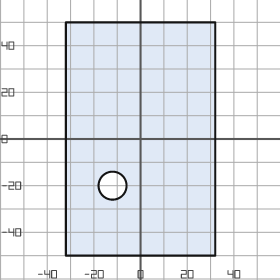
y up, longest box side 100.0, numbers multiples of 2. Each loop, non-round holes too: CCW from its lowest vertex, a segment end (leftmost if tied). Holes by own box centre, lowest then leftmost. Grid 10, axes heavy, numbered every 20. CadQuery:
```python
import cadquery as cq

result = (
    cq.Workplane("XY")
    .moveTo(-32.0, -50.0)
    .lineTo(32.0, -50.0)
    .lineTo(32.0, 50.0)
    .lineTo(-32.0, 50.0)
    .close()
    .moveTo(-12.0, -20.0)
    .circle(6.0)
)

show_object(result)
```